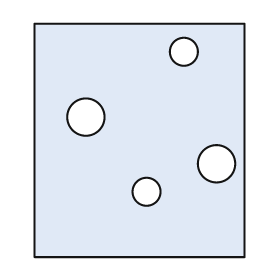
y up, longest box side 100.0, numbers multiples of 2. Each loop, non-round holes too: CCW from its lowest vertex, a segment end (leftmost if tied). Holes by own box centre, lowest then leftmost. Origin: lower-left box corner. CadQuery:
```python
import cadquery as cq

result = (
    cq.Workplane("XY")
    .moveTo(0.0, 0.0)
    .lineTo(90.0, 0.0)
    .lineTo(90.0, 100.0)
    .lineTo(0.0, 100.0)
    .close()
    .moveTo(48.0, 28.0)
    .circle(6.0)
    .moveTo(78.0, 40.0)
    .circle(8.0)
    .moveTo(22.0, 60.0)
    .circle(8.0)
    .moveTo(64.0, 88.0)
    .circle(6.0)
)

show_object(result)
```